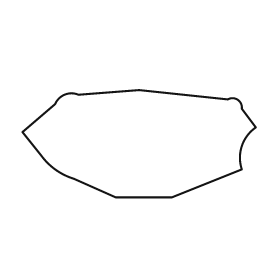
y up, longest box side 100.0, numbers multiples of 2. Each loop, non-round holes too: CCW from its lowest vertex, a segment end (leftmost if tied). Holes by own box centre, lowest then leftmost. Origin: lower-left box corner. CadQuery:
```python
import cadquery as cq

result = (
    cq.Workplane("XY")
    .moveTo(40.0, 0.0)
    .lineTo(64.0, 0.0)
    .lineTo(94.0, 12.0)
    .threePointArc((94.0, 22.0), (100.0, 30.0))
    .lineTo(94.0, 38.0)
    .threePointArc((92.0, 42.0), (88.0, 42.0))
    .lineTo(50.0, 46.0)
    .lineTo(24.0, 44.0)
    .threePointArc((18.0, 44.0), (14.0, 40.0))
    .lineTo(0.0, 28.0)
    .lineTo(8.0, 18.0)
    .threePointArc((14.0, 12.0), (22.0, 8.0))
    .close()
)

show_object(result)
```